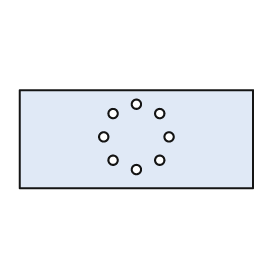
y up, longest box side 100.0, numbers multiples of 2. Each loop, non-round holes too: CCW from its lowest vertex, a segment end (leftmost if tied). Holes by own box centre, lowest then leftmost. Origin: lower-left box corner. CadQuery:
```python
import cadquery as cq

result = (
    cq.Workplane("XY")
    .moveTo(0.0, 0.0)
    .lineTo(100.0, 0.0)
    .lineTo(100.0, 42.0)
    .lineTo(0.0, 42.0)
    .close()
    .moveTo(50.0, 8.0)
    .circle(2.0)
    .moveTo(40.0, 12.0)
    .circle(2.0)
    .moveTo(60.0, 12.0)
    .circle(2.0)
    .moveTo(36.0, 22.0)
    .circle(2.0)
    .moveTo(64.0, 22.0)
    .circle(2.0)
    .moveTo(40.0, 32.0)
    .circle(2.0)
    .moveTo(60.0, 32.0)
    .circle(2.0)
    .moveTo(50.0, 36.0)
    .circle(2.0)
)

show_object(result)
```